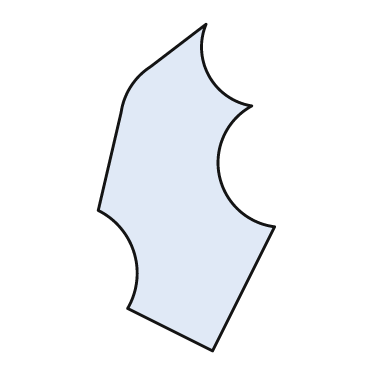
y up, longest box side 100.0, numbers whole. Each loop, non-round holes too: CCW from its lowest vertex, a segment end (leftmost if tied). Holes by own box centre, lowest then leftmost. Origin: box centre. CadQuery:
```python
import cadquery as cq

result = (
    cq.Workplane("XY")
    .moveTo(8.0, -50.0)
    .lineTo(27.0, -12.0)
    .threePointArc((10.0, 4.0), (20.0, 25.0))
    .threePointArc((7.0, 34.0), (6.0, 50.0))
    .lineTo(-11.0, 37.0)
    .threePointArc((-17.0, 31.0), (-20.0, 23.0))
    .lineTo(-27.0, -7.0)
    .threePointArc((-16.0, -20.0), (-18.0, -37.0))
    .close()
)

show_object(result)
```